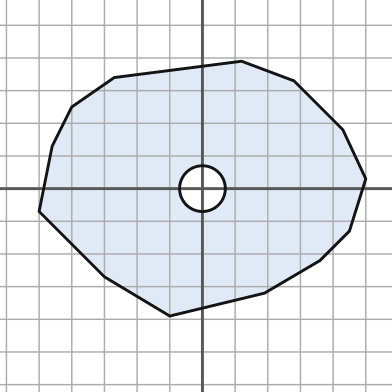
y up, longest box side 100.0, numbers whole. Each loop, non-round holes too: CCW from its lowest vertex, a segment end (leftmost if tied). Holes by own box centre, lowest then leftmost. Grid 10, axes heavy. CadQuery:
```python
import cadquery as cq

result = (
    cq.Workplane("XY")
    .moveTo(-10.0, -39.0)
    .lineTo(19.0, -32.0)
    .lineTo(36.0, -22.0)
    .lineTo(45.0, -13.0)
    .lineTo(50.0, 3.0)
    .lineTo(43.0, 18.0)
    .lineTo(28.0, 33.0)
    .lineTo(12.0, 39.0)
    .lineTo(-27.0, 34.0)
    .lineTo(-40.0, 25.0)
    .lineTo(-46.0, 13.0)
    .lineTo(-50.0, -7.0)
    .lineTo(-30.0, -27.0)
    .close()
    .moveTo(0.0, 0.0)
    .circle(7.0)
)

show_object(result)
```